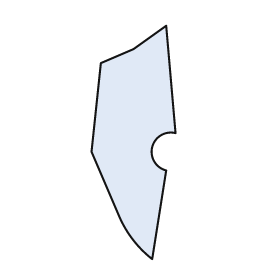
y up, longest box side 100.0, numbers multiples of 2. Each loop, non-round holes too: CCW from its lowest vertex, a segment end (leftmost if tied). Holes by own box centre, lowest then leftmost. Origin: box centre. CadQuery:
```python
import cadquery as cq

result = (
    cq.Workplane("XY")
    .moveTo(8.0, -50.0)
    .lineTo(14.0, -12.0)
    .threePointArc((8.0, -2.0), (18.0, 4.0))
    .lineTo(14.0, 50.0)
    .lineTo(0.0, 40.0)
    .lineTo(-14.0, 34.0)
    .lineTo(-18.0, -4.0)
    .lineTo(-6.0, -32.0)
    .threePointArc((0.0, -42.0), (8.0, -50.0))
    .close()
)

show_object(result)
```